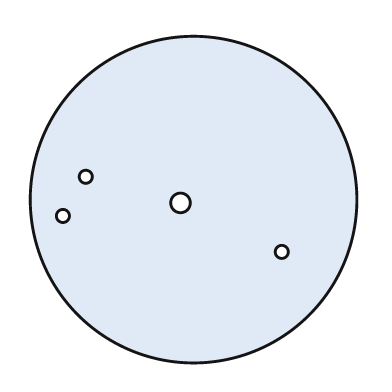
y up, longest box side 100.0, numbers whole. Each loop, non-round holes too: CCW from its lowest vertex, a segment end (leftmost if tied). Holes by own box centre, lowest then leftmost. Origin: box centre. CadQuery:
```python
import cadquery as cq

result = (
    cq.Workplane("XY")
    .moveTo(0.0, 0.0)
    .circle(50.0)
    .moveTo(27.0, -16.0)
    .circle(2.0)
    .moveTo(-40.0, -5.0)
    .circle(2.0)
    .moveTo(-4.0, -1.0)
    .circle(3.0)
    .moveTo(-33.0, 7.0)
    .circle(2.0)
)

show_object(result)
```